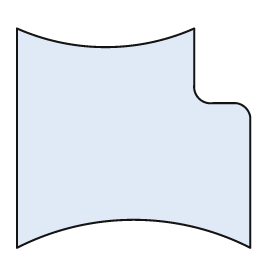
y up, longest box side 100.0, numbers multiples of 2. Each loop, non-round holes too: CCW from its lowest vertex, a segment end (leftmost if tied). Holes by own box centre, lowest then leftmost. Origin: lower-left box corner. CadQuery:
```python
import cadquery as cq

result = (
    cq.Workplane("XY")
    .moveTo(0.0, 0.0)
    .threePointArc((50.0, 12.0), (100.0, 0.0))
    .lineTo(100.0, 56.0)
    .threePointArc((98.0, 60.0), (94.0, 62.0))
    .lineTo(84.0, 62.0)
    .threePointArc((78.0, 64.0), (76.0, 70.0))
    .lineTo(76.0, 94.0)
    .threePointArc((38.0, 86.0), (0.0, 94.0))
    .close()
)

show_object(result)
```